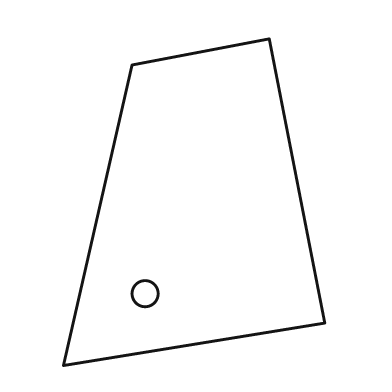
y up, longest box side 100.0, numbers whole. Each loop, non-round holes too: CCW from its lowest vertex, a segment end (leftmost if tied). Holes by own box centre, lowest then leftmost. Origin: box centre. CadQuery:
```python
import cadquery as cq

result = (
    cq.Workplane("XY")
    .moveTo(-40.0, -50.0)
    .lineTo(40.0, -37.0)
    .lineTo(23.0, 50.0)
    .lineTo(-19.0, 42.0)
    .close()
    .moveTo(-15.0, -28.0)
    .circle(4.0)
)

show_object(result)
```